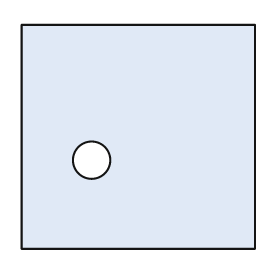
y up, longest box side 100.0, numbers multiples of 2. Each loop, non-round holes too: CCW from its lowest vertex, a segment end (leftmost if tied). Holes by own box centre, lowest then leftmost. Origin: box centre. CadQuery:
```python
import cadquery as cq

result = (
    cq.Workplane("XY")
    .moveTo(-50.0, -48.0)
    .lineTo(50.0, -48.0)
    .lineTo(50.0, 48.0)
    .lineTo(-50.0, 48.0)
    .close()
    .moveTo(-20.0, -10.0)
    .circle(8.0)
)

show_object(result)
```